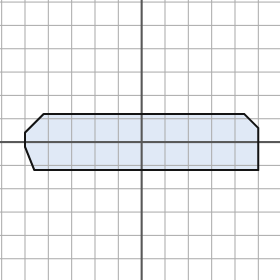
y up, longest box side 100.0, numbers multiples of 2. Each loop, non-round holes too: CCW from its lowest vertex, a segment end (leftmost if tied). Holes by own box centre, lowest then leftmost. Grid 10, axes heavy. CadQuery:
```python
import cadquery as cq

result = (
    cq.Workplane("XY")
    .moveTo(-46.0, -12.0)
    .lineTo(50.0, -12.0)
    .lineTo(50.0, 6.0)
    .lineTo(44.0, 12.0)
    .lineTo(-42.0, 12.0)
    .lineTo(-50.0, 4.0)
    .lineTo(-50.0, -2.0)
    .close()
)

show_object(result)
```